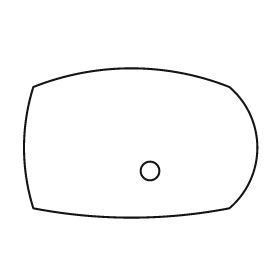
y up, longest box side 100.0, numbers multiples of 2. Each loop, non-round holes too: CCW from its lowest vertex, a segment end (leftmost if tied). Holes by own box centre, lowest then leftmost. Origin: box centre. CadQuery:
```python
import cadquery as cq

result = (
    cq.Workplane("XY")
    .moveTo(-46.0, -28.0)
    .threePointArc((-4.0, -32.0), (38.0, -28.0))
    .threePointArc((50.0, -2.0), (38.0, 24.0))
    .threePointArc((-4.0, 32.0), (-46.0, 24.0))
    .threePointArc((-50.0, -2.0), (-46.0, -28.0))
    .close()
    .moveTo(4.0, -12.0)
    .circle(4.0)
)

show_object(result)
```